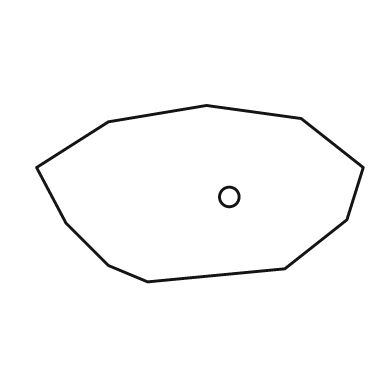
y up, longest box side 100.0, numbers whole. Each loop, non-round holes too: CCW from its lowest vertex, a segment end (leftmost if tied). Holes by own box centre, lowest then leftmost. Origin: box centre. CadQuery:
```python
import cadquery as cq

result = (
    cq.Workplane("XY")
    .moveTo(-16.0, -27.0)
    .lineTo(26.0, -23.0)
    .lineTo(45.0, -8.0)
    .lineTo(50.0, 8.0)
    .lineTo(31.0, 23.0)
    .lineTo(2.0, 27.0)
    .lineTo(-28.0, 22.0)
    .lineTo(-50.0, 8.0)
    .lineTo(-41.0, -9.0)
    .lineTo(-28.0, -22.0)
    .close()
    .moveTo(9.0, -1.0)
    .circle(3.0)
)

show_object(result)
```